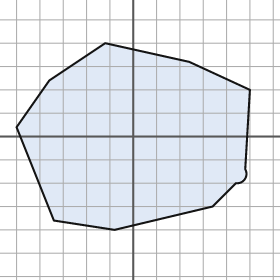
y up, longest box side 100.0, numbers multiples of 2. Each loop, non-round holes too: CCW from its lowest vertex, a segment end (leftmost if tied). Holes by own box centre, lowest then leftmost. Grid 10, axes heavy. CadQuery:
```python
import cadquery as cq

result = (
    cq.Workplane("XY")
    .moveTo(-8.0, -40.0)
    .lineTo(34.0, -30.0)
    .lineTo(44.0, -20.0)
    .threePointArc((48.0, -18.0), (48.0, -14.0))
    .lineTo(50.0, 20.0)
    .lineTo(24.0, 32.0)
    .lineTo(-12.0, 40.0)
    .lineTo(-36.0, 24.0)
    .lineTo(-50.0, 4.0)
    .lineTo(-34.0, -36.0)
    .close()
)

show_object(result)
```